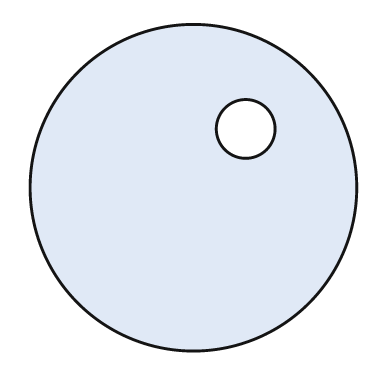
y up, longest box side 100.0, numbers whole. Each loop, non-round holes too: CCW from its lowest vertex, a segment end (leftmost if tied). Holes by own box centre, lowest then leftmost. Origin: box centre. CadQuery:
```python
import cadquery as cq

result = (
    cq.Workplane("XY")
    .moveTo(0.0, 0.0)
    .circle(50.0)
    .moveTo(16.0, 18.0)
    .circle(9.0)
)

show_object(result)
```